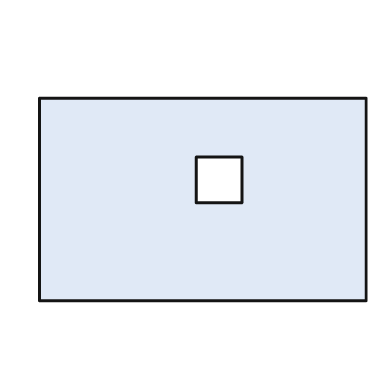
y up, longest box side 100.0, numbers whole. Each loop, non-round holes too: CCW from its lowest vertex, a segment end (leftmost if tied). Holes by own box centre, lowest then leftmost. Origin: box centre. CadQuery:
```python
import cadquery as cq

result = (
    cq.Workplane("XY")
    .moveTo(-50.0, -31.0)
    .lineTo(50.0, -31.0)
    .lineTo(50.0, 31.0)
    .lineTo(-50.0, 31.0)
    .close()
    .moveTo(-2.0, -1.0)
    .lineTo(12.0, -1.0)
    .lineTo(12.0, 13.0)
    .lineTo(-2.0, 13.0)
    .close()
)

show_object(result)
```